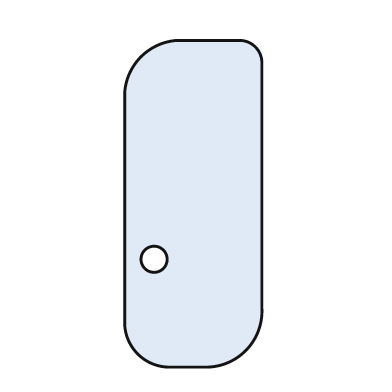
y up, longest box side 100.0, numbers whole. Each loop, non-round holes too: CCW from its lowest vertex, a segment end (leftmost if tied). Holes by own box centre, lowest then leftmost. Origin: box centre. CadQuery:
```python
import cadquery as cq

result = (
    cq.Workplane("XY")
    .moveTo(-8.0, -50.0)
    .lineTo(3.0, -50.0)
    .threePointArc((16.0, -45.0), (21.0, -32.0))
    .lineTo(21.0, 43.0)
    .threePointArc((19.0, 48.0), (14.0, 50.0))
    .lineTo(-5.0, 50.0)
    .threePointArc((-16.0, 45.0), (-21.0, 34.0))
    .lineTo(-21.0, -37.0)
    .threePointArc((-17.0, -46.0), (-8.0, -50.0))
    .close()
    .moveTo(-12.0, -17.0)
    .circle(4.0)
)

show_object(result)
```